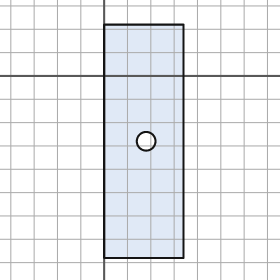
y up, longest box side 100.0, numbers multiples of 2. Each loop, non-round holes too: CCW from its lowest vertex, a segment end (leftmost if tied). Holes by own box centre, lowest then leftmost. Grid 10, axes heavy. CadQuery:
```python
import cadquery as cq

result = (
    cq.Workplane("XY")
    .moveTo(0.0, -78.0)
    .lineTo(34.0, -78.0)
    .lineTo(34.0, 22.0)
    .lineTo(0.0, 22.0)
    .close()
    .moveTo(18.0, -28.0)
    .circle(4.0)
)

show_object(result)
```